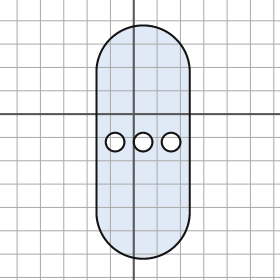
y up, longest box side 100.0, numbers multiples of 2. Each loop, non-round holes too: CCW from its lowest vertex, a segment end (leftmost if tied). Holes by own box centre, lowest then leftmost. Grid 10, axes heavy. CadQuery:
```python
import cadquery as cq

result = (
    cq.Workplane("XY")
    .moveTo(-16.0, -42.0)
    .threePointArc((4.0, -62.0), (24.0, -42.0))
    .lineTo(24.0, 18.0)
    .threePointArc((4.0, 38.0), (-16.0, 18.0))
    .close()
    .moveTo(-8.0, -12.0)
    .circle(4.0)
    .moveTo(4.0, -12.0)
    .circle(4.0)
    .moveTo(16.0, -12.0)
    .circle(4.0)
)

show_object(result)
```